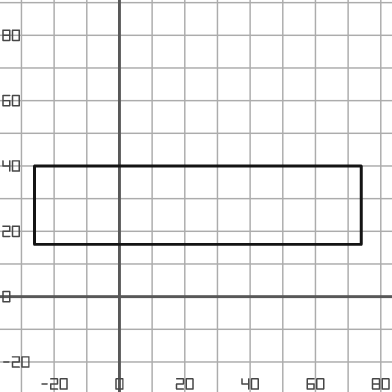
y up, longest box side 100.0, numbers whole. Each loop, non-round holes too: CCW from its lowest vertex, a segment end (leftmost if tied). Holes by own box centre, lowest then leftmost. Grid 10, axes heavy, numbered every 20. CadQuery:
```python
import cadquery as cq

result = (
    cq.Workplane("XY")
    .moveTo(-26.0, 16.0)
    .lineTo(74.0, 16.0)
    .lineTo(74.0, 40.0)
    .lineTo(-26.0, 40.0)
    .close()
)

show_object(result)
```